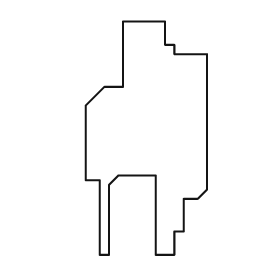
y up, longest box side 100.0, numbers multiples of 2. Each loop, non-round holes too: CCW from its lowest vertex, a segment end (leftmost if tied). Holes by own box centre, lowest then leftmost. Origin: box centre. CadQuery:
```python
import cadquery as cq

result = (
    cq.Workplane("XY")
    .moveTo(-20.0, -50.0)
    .lineTo(-16.0, -50.0)
    .lineTo(-16.0, -20.0)
    .lineTo(-12.0, -16.0)
    .lineTo(4.0, -16.0)
    .lineTo(4.0, -50.0)
    .lineTo(12.0, -50.0)
    .lineTo(12.0, -40.0)
    .lineTo(16.0, -40.0)
    .lineTo(16.0, -26.0)
    .lineTo(22.0, -26.0)
    .lineTo(26.0, -22.0)
    .lineTo(26.0, 36.0)
    .lineTo(12.0, 36.0)
    .lineTo(12.0, 40.0)
    .lineTo(8.0, 40.0)
    .lineTo(8.0, 50.0)
    .lineTo(-10.0, 50.0)
    .lineTo(-10.0, 22.0)
    .lineTo(-18.0, 22.0)
    .lineTo(-26.0, 14.0)
    .lineTo(-26.0, -18.0)
    .lineTo(-20.0, -18.0)
    .close()
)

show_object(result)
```